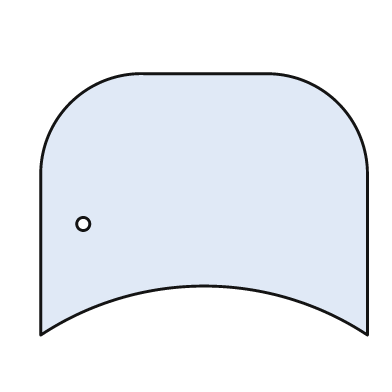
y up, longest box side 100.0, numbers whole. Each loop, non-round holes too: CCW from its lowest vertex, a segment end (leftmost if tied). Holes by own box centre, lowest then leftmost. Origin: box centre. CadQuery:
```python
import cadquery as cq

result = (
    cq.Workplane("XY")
    .moveTo(-50.0, -40.0)
    .threePointArc((0.0, -25.0), (50.0, -40.0))
    .lineTo(50.0, 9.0)
    .threePointArc((41.0, 31.0), (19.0, 40.0))
    .lineTo(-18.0, 40.0)
    .threePointArc((-41.0, 31.0), (-50.0, 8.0))
    .close()
    .moveTo(-37.0, -6.0)
    .circle(2.0)
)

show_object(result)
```